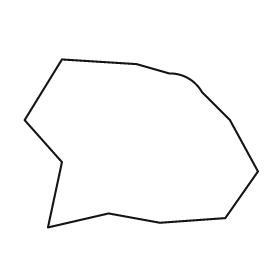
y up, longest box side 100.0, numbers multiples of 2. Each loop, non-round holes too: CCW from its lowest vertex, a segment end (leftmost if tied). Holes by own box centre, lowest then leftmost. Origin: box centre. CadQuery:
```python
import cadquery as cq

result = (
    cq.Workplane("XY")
    .moveTo(-40.0, -36.0)
    .lineTo(-14.0, -30.0)
    .lineTo(8.0, -34.0)
    .lineTo(36.0, -32.0)
    .lineTo(50.0, -12.0)
    .lineTo(38.0, 10.0)
    .lineTo(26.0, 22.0)
    .threePointArc((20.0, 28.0), (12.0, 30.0))
    .lineTo(-2.0, 34.0)
    .lineTo(-34.0, 36.0)
    .lineTo(-50.0, 10.0)
    .lineTo(-34.0, -8.0)
    .close()
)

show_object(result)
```